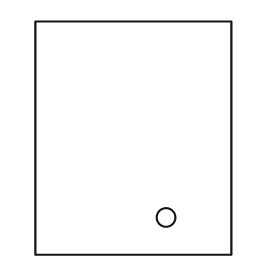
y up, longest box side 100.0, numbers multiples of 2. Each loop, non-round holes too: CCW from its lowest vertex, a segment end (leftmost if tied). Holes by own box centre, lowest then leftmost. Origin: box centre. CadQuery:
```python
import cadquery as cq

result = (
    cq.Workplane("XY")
    .moveTo(-42.0, -50.0)
    .lineTo(42.0, -50.0)
    .lineTo(42.0, 50.0)
    .lineTo(-42.0, 50.0)
    .close()
    .moveTo(14.0, -34.0)
    .circle(4.0)
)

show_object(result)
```